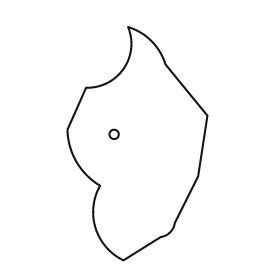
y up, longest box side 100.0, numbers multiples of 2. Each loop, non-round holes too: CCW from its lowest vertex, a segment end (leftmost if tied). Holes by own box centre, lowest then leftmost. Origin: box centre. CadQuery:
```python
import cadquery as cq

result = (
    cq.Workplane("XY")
    .moveTo(-6.0, -50.0)
    .lineTo(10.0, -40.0)
    .threePointArc((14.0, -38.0), (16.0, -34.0))
    .lineTo(26.0, -14.0)
    .lineTo(30.0, 12.0)
    .lineTo(12.0, 34.0)
    .threePointArc((6.0, 44.0), (-4.0, 50.0))
    .threePointArc((-6.0, 32.0), (-22.0, 24.0))
    .lineTo(-30.0, 6.0)
    .threePointArc((-26.0, -8.0), (-16.0, -18.0))
    .threePointArc((-18.0, -36.0), (-6.0, -50.0))
    .close()
    .moveTo(-10.0, 4.0)
    .circle(2.0)
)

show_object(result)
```